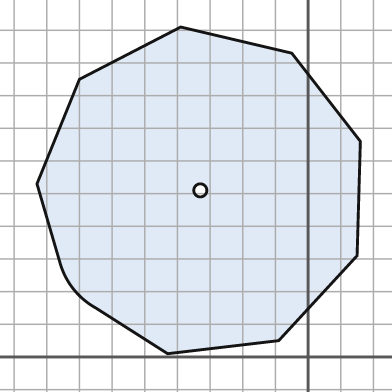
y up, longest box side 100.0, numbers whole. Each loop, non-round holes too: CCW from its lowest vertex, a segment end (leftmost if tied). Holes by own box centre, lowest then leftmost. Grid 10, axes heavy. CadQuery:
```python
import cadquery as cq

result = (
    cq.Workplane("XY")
    .moveTo(-43.0, 1.0)
    .lineTo(-9.0, 5.0)
    .lineTo(15.0, 31.0)
    .lineTo(16.0, 66.0)
    .lineTo(-5.0, 93.0)
    .lineTo(-39.0, 101.0)
    .lineTo(-70.0, 85.0)
    .lineTo(-83.0, 53.0)
    .lineTo(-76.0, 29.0)
    .threePointArc((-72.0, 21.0), (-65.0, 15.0))
    .close()
    .moveTo(-33.0, 51.0)
    .circle(2.0)
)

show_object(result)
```